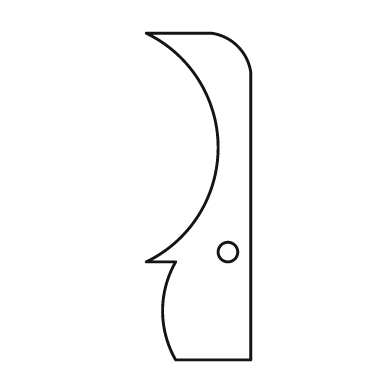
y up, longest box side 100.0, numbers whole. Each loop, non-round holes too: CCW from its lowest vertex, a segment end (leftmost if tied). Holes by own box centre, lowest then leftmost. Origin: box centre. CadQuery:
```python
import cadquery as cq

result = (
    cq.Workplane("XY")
    .moveTo(-7.0, -50.0)
    .lineTo(16.0, -50.0)
    .lineTo(16.0, 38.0)
    .threePointArc((12.0, 46.0), (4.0, 50.0))
    .lineTo(-16.0, 50.0)
    .threePointArc((6.0, 15.0), (-16.0, -20.0))
    .lineTo(-7.0, -20.0)
    .threePointArc((-11.0, -35.0), (-7.0, -50.0))
    .close()
    .moveTo(9.0, -17.0)
    .circle(3.0)
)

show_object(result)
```